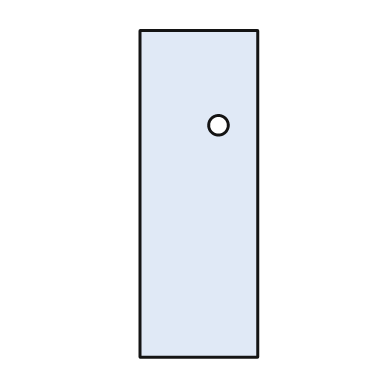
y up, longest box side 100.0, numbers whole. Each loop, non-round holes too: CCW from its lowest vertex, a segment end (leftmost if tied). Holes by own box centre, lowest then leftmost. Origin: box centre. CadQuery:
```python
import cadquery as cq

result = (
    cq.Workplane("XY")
    .moveTo(-18.0, -50.0)
    .lineTo(18.0, -50.0)
    .lineTo(18.0, 50.0)
    .lineTo(-18.0, 50.0)
    .close()
    .moveTo(6.0, 21.0)
    .circle(3.0)
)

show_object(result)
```